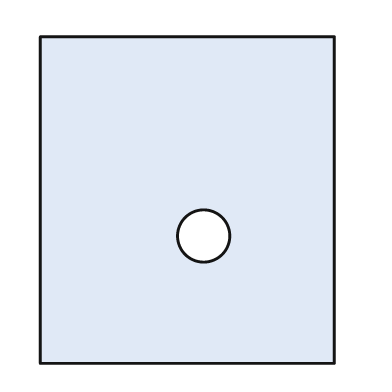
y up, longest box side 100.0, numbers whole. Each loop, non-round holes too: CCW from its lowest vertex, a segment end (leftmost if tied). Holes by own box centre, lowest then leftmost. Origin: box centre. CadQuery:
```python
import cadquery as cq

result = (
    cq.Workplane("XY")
    .moveTo(-45.0, -50.0)
    .lineTo(45.0, -50.0)
    .lineTo(45.0, 50.0)
    .lineTo(-45.0, 50.0)
    .close()
    .moveTo(5.0, -11.0)
    .circle(8.0)
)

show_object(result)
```